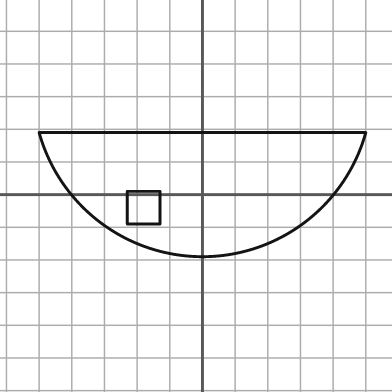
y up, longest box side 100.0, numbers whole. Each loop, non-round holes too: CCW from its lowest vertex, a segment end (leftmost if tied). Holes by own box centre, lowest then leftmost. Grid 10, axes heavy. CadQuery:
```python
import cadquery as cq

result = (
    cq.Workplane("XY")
    .moveTo(-50.0, 19.0)
    .threePointArc((0.0, -19.0), (50.0, 19.0))
    .close()
    .moveTo(-23.0, -9.0)
    .lineTo(-13.0, -9.0)
    .lineTo(-13.0, 1.0)
    .lineTo(-23.0, 1.0)
    .close()
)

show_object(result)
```